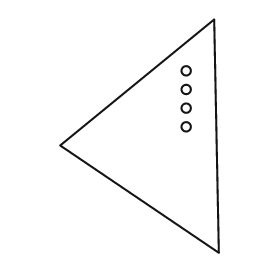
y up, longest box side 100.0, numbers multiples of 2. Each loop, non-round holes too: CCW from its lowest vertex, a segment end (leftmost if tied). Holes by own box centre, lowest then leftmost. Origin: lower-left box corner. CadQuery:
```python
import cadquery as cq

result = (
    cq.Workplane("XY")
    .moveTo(68.0, 0.0)
    .lineTo(66.0, 100.0)
    .lineTo(0.0, 46.0)
    .close()
    .moveTo(54.0, 54.0)
    .circle(2.0)
    .moveTo(54.0, 62.0)
    .circle(2.0)
    .moveTo(54.0, 70.0)
    .circle(2.0)
    .moveTo(54.0, 78.0)
    .circle(2.0)
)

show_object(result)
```